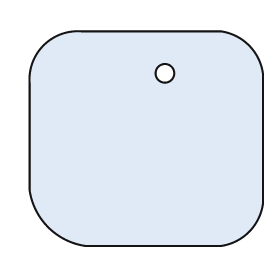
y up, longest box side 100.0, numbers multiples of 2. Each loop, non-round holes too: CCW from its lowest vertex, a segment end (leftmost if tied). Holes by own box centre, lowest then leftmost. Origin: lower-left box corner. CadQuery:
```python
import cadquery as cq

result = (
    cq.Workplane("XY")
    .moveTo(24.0, 0.0)
    .lineTo(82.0, 0.0)
    .threePointArc((94.0, 6.0), (100.0, 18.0))
    .lineTo(100.0, 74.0)
    .threePointArc((94.0, 86.0), (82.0, 92.0))
    .lineTo(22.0, 92.0)
    .threePointArc((6.0, 86.0), (0.0, 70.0))
    .lineTo(0.0, 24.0)
    .threePointArc((8.0, 8.0), (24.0, 0.0))
    .close()
    .moveTo(58.0, 74.0)
    .circle(4.0)
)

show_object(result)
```